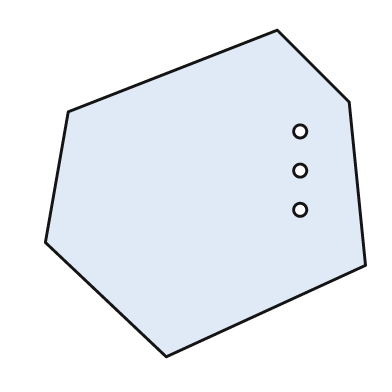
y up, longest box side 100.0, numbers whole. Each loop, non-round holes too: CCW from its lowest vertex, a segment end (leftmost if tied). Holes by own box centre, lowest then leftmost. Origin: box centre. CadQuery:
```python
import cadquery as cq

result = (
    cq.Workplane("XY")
    .moveTo(-12.0, -50.0)
    .lineTo(49.0, -22.0)
    .lineTo(44.0, 28.0)
    .lineTo(22.0, 50.0)
    .lineTo(-42.0, 25.0)
    .lineTo(-49.0, -15.0)
    .close()
    .moveTo(29.0, -5.0)
    .circle(2.0)
    .moveTo(29.0, 7.0)
    .circle(2.0)
    .moveTo(29.0, 19.0)
    .circle(2.0)
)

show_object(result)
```